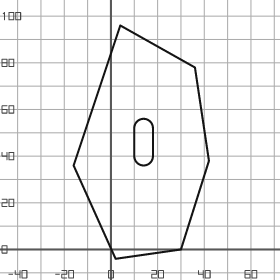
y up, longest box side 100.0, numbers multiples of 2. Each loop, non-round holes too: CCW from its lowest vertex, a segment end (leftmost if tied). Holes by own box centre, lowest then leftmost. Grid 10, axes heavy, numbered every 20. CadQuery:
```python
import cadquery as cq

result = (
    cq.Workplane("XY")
    .moveTo(2.0, -4.0)
    .lineTo(30.0, 0.0)
    .lineTo(42.0, 38.0)
    .lineTo(36.0, 78.0)
    .lineTo(4.0, 96.0)
    .lineTo(-16.0, 36.0)
    .close()
    .moveTo(10.0, 40.0)
    .threePointArc((14.0, 36.0), (18.0, 40.0))
    .lineTo(18.0, 52.0)
    .threePointArc((14.0, 56.0), (10.0, 52.0))
    .close()
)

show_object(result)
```